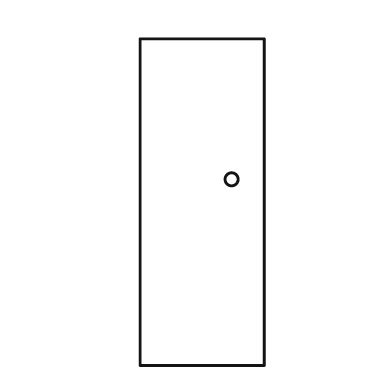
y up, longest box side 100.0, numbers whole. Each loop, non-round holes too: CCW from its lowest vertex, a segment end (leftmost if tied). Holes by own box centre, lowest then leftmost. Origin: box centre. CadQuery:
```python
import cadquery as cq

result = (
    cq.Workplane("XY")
    .moveTo(-19.0, -50.0)
    .lineTo(19.0, -50.0)
    .lineTo(19.0, 50.0)
    .lineTo(-19.0, 50.0)
    .close()
    .moveTo(9.0, 7.0)
    .circle(2.0)
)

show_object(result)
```